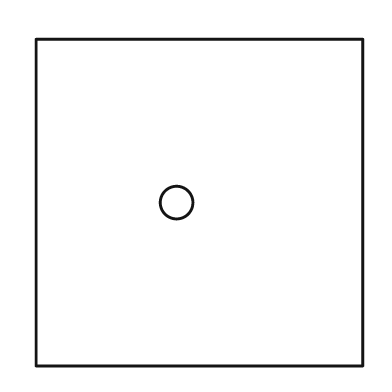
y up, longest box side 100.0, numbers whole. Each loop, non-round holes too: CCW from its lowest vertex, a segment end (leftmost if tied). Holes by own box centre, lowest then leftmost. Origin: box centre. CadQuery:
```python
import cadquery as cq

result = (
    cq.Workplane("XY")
    .moveTo(-50.0, -50.0)
    .lineTo(50.0, -50.0)
    .lineTo(50.0, 50.0)
    .lineTo(-50.0, 50.0)
    .close()
    .moveTo(-7.0, 0.0)
    .circle(5.0)
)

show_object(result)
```